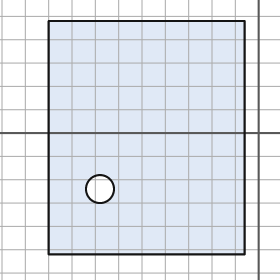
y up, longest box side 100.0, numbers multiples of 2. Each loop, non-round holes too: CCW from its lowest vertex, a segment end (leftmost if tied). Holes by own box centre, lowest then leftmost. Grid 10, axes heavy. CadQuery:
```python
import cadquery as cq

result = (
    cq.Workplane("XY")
    .moveTo(-90.0, -52.0)
    .lineTo(-6.0, -52.0)
    .lineTo(-6.0, 48.0)
    .lineTo(-90.0, 48.0)
    .close()
    .moveTo(-68.0, -24.0)
    .circle(6.0)
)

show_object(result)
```